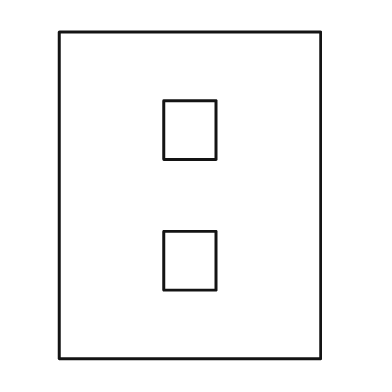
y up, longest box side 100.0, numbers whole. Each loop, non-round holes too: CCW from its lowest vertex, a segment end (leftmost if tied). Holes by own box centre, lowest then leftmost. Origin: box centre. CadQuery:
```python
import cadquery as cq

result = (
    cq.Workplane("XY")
    .moveTo(-40.0, -50.0)
    .lineTo(40.0, -50.0)
    .lineTo(40.0, 50.0)
    .lineTo(-40.0, 50.0)
    .close()
    .moveTo(-8.0, -29.0)
    .lineTo(8.0, -29.0)
    .lineTo(8.0, -11.0)
    .lineTo(-8.0, -11.0)
    .close()
    .moveTo(-8.0, 11.0)
    .lineTo(8.0, 11.0)
    .lineTo(8.0, 29.0)
    .lineTo(-8.0, 29.0)
    .close()
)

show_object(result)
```